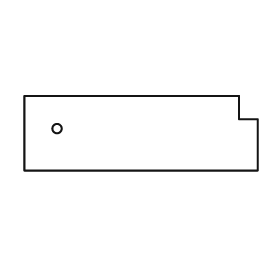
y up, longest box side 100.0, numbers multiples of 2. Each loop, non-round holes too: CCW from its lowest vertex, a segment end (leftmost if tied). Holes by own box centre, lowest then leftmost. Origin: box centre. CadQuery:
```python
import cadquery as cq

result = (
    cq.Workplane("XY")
    .moveTo(-50.0, -16.0)
    .lineTo(50.0, -16.0)
    .lineTo(50.0, 6.0)
    .lineTo(42.0, 6.0)
    .lineTo(42.0, 16.0)
    .lineTo(-50.0, 16.0)
    .close()
    .moveTo(-36.0, 2.0)
    .circle(2.0)
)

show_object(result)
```